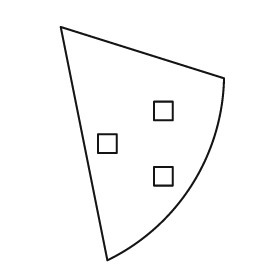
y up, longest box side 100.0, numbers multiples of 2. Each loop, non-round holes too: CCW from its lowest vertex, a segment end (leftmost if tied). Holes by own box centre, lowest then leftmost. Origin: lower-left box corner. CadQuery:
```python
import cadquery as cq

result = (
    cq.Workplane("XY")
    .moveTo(20.0, 0.0)
    .threePointArc((56.0, 32.0), (70.0, 78.0))
    .lineTo(0.0, 100.0)
    .close()
    .moveTo(40.0, 32.0)
    .lineTo(48.0, 32.0)
    .lineTo(48.0, 40.0)
    .lineTo(40.0, 40.0)
    .close()
    .moveTo(16.0, 46.0)
    .lineTo(24.0, 46.0)
    .lineTo(24.0, 54.0)
    .lineTo(16.0, 54.0)
    .close()
    .moveTo(40.0, 60.0)
    .lineTo(48.0, 60.0)
    .lineTo(48.0, 68.0)
    .lineTo(40.0, 68.0)
    .close()
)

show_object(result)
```